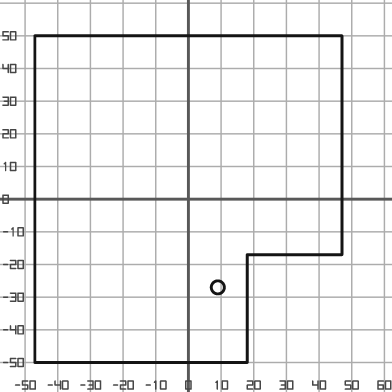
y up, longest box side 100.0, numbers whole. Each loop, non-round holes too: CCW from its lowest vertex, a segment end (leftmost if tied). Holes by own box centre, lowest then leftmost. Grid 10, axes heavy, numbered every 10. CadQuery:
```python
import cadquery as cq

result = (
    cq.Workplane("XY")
    .moveTo(-47.0, -50.0)
    .lineTo(18.0, -50.0)
    .lineTo(18.0, -17.0)
    .lineTo(47.0, -17.0)
    .lineTo(47.0, 50.0)
    .lineTo(-47.0, 50.0)
    .close()
    .moveTo(9.0, -27.0)
    .circle(2.0)
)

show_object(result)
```